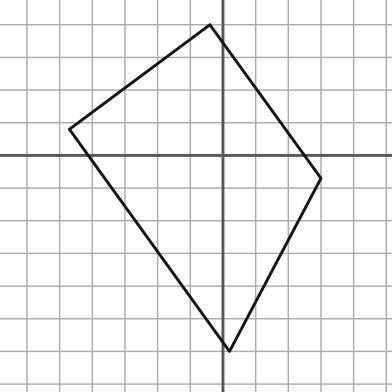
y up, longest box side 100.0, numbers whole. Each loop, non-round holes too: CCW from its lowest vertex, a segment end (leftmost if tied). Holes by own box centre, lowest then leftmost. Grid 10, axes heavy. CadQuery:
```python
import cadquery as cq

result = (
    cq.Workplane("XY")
    .moveTo(2.0, -60.0)
    .lineTo(30.0, -7.0)
    .lineTo(-4.0, 40.0)
    .lineTo(-47.0, 8.0)
    .close()
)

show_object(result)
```